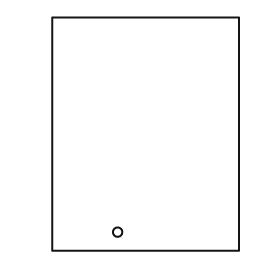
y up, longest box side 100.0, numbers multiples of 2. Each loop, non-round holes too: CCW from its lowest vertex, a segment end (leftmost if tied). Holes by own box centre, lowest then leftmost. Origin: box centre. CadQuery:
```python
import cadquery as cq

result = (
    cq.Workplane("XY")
    .moveTo(-40.0, -50.0)
    .lineTo(40.0, -50.0)
    .lineTo(40.0, 50.0)
    .lineTo(-40.0, 50.0)
    .close()
    .moveTo(-12.0, -42.0)
    .circle(2.0)
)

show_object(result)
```